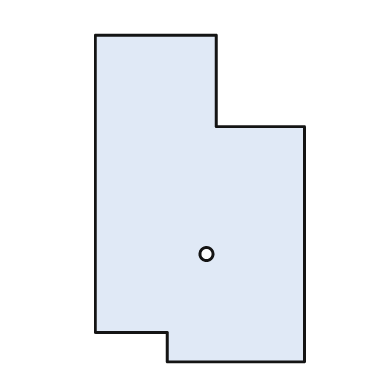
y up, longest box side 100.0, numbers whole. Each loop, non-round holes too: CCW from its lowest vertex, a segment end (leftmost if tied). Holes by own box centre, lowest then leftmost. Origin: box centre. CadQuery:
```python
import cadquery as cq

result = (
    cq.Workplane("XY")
    .moveTo(-10.0, -50.0)
    .lineTo(32.0, -50.0)
    .lineTo(32.0, 22.0)
    .lineTo(5.0, 22.0)
    .lineTo(5.0, 50.0)
    .lineTo(-32.0, 50.0)
    .lineTo(-32.0, -41.0)
    .lineTo(-10.0, -41.0)
    .close()
    .moveTo(2.0, -17.0)
    .circle(2.0)
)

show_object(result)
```